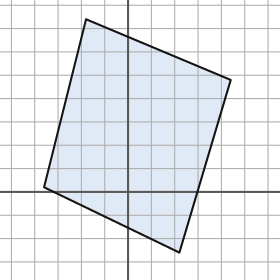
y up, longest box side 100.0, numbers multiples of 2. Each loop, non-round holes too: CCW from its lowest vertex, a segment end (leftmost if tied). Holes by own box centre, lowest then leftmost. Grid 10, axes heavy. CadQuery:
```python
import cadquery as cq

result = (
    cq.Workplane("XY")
    .moveTo(22.0, -26.0)
    .lineTo(44.0, 48.0)
    .lineTo(-18.0, 74.0)
    .lineTo(-36.0, 2.0)
    .close()
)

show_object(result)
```